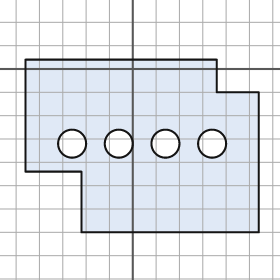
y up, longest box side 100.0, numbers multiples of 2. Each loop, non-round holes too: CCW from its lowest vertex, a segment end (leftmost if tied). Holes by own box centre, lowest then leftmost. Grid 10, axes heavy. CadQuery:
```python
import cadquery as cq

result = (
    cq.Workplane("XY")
    .moveTo(-22.0, -70.0)
    .lineTo(54.0, -70.0)
    .lineTo(54.0, -10.0)
    .lineTo(36.0, -10.0)
    .lineTo(36.0, 4.0)
    .lineTo(-46.0, 4.0)
    .lineTo(-46.0, -44.0)
    .lineTo(-22.0, -44.0)
    .close()
    .moveTo(-26.0, -32.0)
    .circle(6.0)
    .moveTo(-6.0, -32.0)
    .circle(6.0)
    .moveTo(14.0, -32.0)
    .circle(6.0)
    .moveTo(34.0, -32.0)
    .circle(6.0)
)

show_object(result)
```